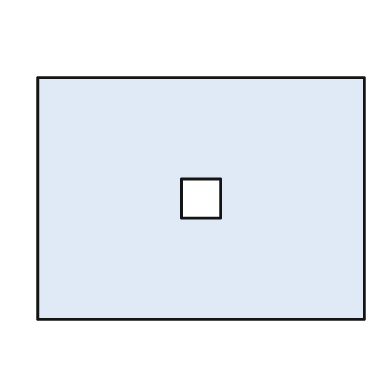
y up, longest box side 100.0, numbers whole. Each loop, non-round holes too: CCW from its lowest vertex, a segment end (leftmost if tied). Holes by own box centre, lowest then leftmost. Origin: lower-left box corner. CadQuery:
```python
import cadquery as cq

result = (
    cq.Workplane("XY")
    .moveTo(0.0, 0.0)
    .lineTo(100.0, 0.0)
    .lineTo(100.0, 74.0)
    .lineTo(0.0, 74.0)
    .close()
    .moveTo(44.0, 31.0)
    .lineTo(56.0, 31.0)
    .lineTo(56.0, 43.0)
    .lineTo(44.0, 43.0)
    .close()
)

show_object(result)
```